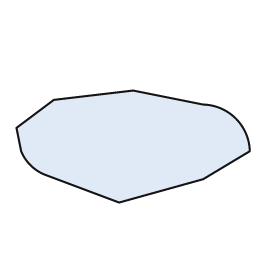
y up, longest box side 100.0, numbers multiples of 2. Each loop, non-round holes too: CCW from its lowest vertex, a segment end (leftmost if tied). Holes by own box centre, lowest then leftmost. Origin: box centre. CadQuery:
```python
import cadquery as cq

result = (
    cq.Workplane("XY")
    .moveTo(-6.0, -24.0)
    .lineTo(30.0, -14.0)
    .lineTo(50.0, -2.0)
    .threePointArc((44.0, 12.0), (30.0, 18.0))
    .lineTo(0.0, 24.0)
    .lineTo(-34.0, 20.0)
    .lineTo(-50.0, 8.0)
    .lineTo(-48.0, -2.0)
    .threePointArc((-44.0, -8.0), (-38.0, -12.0))
    .close()
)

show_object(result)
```